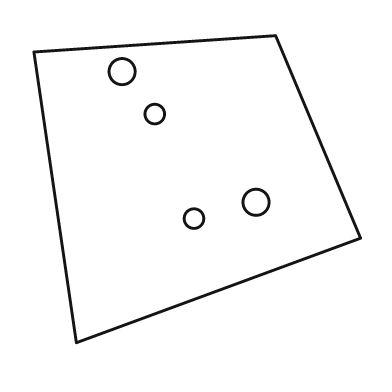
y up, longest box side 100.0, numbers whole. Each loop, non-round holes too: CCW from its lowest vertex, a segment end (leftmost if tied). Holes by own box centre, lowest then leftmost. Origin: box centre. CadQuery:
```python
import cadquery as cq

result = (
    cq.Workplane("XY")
    .moveTo(-37.0, -47.0)
    .lineTo(50.0, -15.0)
    .lineTo(24.0, 47.0)
    .lineTo(-50.0, 42.0)
    .close()
    .moveTo(-1.0, -9.0)
    .circle(3.0)
    .moveTo(18.0, -4.0)
    .circle(4.0)
    .moveTo(-13.0, 23.0)
    .circle(3.0)
    .moveTo(-23.0, 36.0)
    .circle(4.0)
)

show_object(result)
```